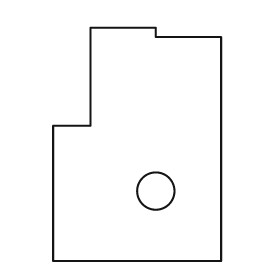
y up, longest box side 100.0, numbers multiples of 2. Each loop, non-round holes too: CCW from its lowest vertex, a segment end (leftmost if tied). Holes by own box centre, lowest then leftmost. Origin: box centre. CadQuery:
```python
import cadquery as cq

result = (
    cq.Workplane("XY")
    .moveTo(-36.0, -50.0)
    .lineTo(36.0, -50.0)
    .lineTo(36.0, 46.0)
    .lineTo(8.0, 46.0)
    .lineTo(8.0, 50.0)
    .lineTo(-20.0, 50.0)
    .lineTo(-20.0, 8.0)
    .lineTo(-36.0, 8.0)
    .close()
    .moveTo(8.0, -20.0)
    .circle(8.0)
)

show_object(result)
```